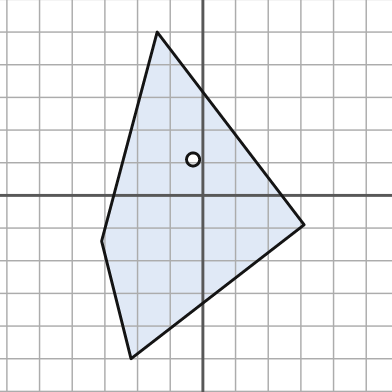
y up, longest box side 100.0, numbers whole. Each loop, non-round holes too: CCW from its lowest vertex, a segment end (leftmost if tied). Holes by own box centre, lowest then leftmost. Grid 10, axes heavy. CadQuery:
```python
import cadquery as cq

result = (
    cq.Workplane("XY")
    .moveTo(-22.0, -50.0)
    .lineTo(31.0, -9.0)
    .lineTo(-14.0, 50.0)
    .lineTo(-31.0, -14.0)
    .close()
    .moveTo(-3.0, 11.0)
    .circle(2.0)
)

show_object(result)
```